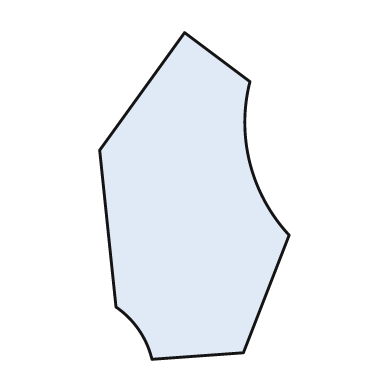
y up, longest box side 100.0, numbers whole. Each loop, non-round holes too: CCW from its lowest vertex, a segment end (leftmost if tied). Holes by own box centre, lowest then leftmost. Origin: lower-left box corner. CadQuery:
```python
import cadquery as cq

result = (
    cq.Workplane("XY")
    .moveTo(16.0, 0.0)
    .lineTo(44.0, 2.0)
    .lineTo(58.0, 38.0)
    .threePointArc((46.0, 60.0), (46.0, 85.0))
    .lineTo(26.0, 100.0)
    .lineTo(0.0, 64.0)
    .lineTo(5.0, 16.0)
    .threePointArc((12.0, 9.0), (16.0, 0.0))
    .close()
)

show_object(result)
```